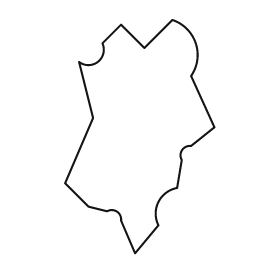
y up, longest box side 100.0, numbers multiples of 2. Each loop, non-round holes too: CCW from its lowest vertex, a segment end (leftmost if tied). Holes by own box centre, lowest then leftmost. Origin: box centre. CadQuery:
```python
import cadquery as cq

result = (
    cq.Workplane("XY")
    .moveTo(-2.0, -50.0)
    .lineTo(8.0, -38.0)
    .threePointArc((8.0, -28.0), (16.0, -22.0))
    .lineTo(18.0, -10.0)
    .threePointArc((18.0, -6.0), (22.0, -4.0))
    .lineTo(32.0, 4.0)
    .lineTo(22.0, 26.0)
    .threePointArc((24.0, 40.0), (14.0, 50.0))
    .lineTo(2.0, 38.0)
    .lineTo(-8.0, 48.0)
    .lineTo(-16.0, 40.0)
    .threePointArc((-18.0, 32.0), (-26.0, 32.0))
    .lineTo(-20.0, 8.0)
    .lineTo(-32.0, -20.0)
    .lineTo(-22.0, -30.0)
    .lineTo(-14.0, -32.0)
    .threePointArc((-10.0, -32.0), (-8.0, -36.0))
    .close()
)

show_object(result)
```